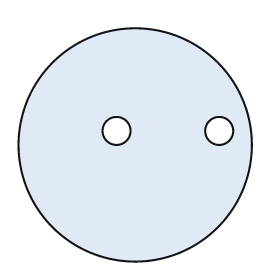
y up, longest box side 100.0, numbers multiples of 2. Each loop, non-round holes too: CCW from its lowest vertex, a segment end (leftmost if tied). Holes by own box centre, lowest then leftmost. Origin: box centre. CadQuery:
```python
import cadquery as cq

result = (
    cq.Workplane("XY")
    .moveTo(0.0, 0.0)
    .circle(50.0)
    .moveTo(-8.0, 6.0)
    .circle(6.0)
    .moveTo(36.0, 6.0)
    .circle(6.0)
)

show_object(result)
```